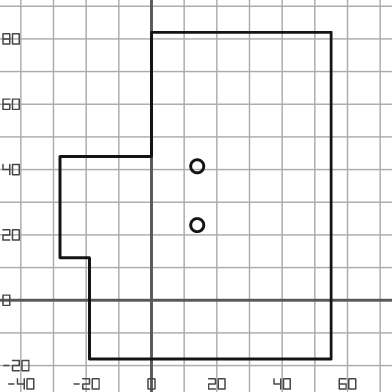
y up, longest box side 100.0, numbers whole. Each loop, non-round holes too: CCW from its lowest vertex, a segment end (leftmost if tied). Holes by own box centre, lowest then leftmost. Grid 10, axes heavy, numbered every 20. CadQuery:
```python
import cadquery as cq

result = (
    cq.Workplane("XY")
    .moveTo(-19.0, -18.0)
    .lineTo(55.0, -18.0)
    .lineTo(55.0, 82.0)
    .lineTo(0.0, 82.0)
    .lineTo(0.0, 44.0)
    .lineTo(-28.0, 44.0)
    .lineTo(-28.0, 13.0)
    .lineTo(-19.0, 13.0)
    .close()
    .moveTo(14.0, 23.0)
    .circle(2.0)
    .moveTo(14.0, 41.0)
    .circle(2.0)
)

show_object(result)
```